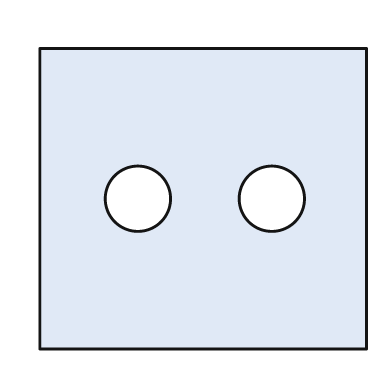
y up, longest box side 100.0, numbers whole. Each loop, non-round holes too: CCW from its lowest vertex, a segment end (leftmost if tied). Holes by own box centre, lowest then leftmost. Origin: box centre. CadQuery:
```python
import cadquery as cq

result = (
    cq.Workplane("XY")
    .moveTo(-50.0, -46.0)
    .lineTo(50.0, -46.0)
    .lineTo(50.0, 46.0)
    .lineTo(-50.0, 46.0)
    .close()
    .moveTo(-20.0, 0.0)
    .circle(10.0)
    .moveTo(21.0, 0.0)
    .circle(10.0)
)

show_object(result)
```